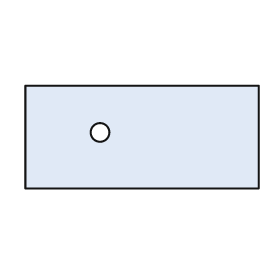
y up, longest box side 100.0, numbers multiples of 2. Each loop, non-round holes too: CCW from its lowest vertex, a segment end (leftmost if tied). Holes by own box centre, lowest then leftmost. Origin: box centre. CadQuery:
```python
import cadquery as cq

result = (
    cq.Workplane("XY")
    .moveTo(-50.0, -22.0)
    .lineTo(50.0, -22.0)
    .lineTo(50.0, 22.0)
    .lineTo(-50.0, 22.0)
    .close()
    .moveTo(-18.0, 2.0)
    .circle(4.0)
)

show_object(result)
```